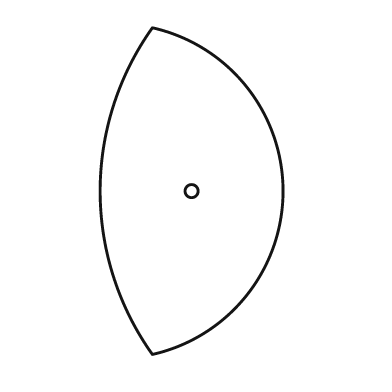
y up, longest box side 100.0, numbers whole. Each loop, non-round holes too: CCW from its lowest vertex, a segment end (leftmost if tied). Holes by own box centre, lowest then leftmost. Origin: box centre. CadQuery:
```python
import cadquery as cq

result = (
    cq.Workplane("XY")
    .moveTo(-12.0, -50.0)
    .threePointArc((28.0, 0.0), (-12.0, 50.0))
    .threePointArc((-28.0, 0.0), (-12.0, -50.0))
    .close()
    .moveTo(0.0, 0.0)
    .circle(2.0)
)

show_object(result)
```